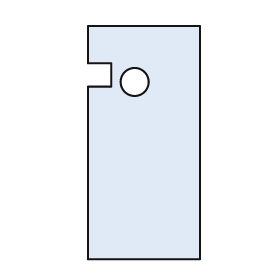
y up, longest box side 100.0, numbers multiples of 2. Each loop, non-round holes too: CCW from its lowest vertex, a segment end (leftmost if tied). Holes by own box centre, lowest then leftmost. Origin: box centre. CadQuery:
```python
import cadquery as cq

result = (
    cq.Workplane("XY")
    .moveTo(-24.0, -50.0)
    .lineTo(24.0, -50.0)
    .lineTo(24.0, 50.0)
    .lineTo(-24.0, 50.0)
    .lineTo(-24.0, 34.0)
    .lineTo(-14.0, 34.0)
    .lineTo(-14.0, 24.0)
    .lineTo(-24.0, 24.0)
    .close()
    .moveTo(-4.0, 26.0)
    .circle(6.0)
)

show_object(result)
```